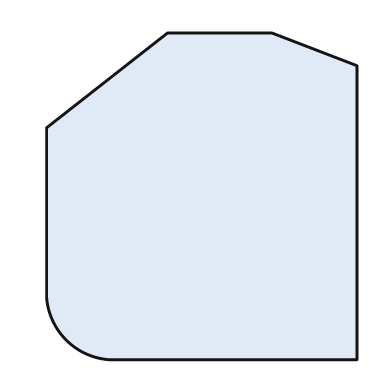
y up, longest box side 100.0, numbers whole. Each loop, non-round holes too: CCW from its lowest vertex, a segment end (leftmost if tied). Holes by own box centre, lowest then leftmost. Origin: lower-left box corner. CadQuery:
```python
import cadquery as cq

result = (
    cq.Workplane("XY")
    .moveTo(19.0, 0.0)
    .lineTo(95.0, 0.0)
    .lineTo(95.0, 90.0)
    .lineTo(69.0, 100.0)
    .lineTo(37.0, 100.0)
    .lineTo(0.0, 71.0)
    .lineTo(0.0, 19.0)
    .threePointArc((6.0, 6.0), (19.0, 0.0))
    .close()
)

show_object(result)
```